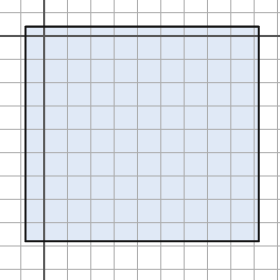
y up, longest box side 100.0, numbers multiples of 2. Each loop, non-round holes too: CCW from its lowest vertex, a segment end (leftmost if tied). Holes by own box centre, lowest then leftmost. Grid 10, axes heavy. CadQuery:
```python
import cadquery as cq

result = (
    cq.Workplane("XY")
    .moveTo(-8.0, -88.0)
    .lineTo(92.0, -88.0)
    .lineTo(92.0, 4.0)
    .lineTo(-8.0, 4.0)
    .close()
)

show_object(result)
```